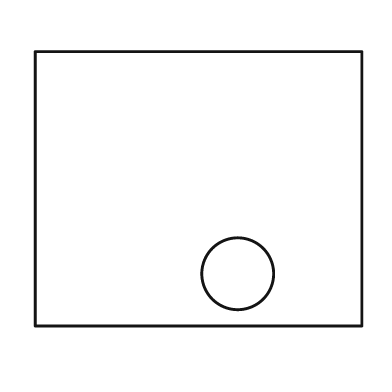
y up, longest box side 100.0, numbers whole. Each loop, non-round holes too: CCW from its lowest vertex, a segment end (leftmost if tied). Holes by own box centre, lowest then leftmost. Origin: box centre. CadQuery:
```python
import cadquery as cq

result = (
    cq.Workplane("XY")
    .moveTo(-50.0, -42.0)
    .lineTo(50.0, -42.0)
    .lineTo(50.0, 42.0)
    .lineTo(-50.0, 42.0)
    .close()
    .moveTo(12.0, -26.0)
    .circle(11.0)
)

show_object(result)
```